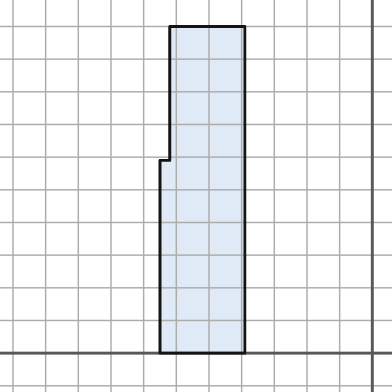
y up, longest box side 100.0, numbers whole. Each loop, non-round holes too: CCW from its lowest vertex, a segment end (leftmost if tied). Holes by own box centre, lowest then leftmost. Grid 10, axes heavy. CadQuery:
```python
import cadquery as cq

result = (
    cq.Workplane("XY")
    .moveTo(-65.0, 0.0)
    .lineTo(-39.0, 0.0)
    .lineTo(-39.0, 100.0)
    .lineTo(-62.0, 100.0)
    .lineTo(-62.0, 59.0)
    .lineTo(-65.0, 59.0)
    .close()
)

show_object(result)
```